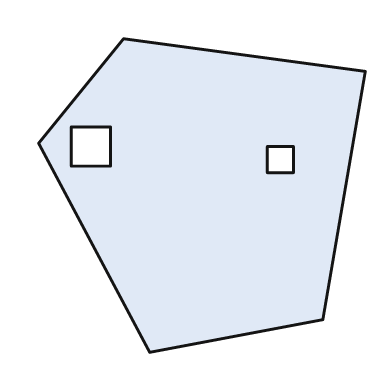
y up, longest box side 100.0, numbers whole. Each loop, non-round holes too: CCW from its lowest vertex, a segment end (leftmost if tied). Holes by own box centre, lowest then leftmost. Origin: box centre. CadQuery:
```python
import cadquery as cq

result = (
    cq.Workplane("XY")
    .moveTo(-16.0, -48.0)
    .lineTo(37.0, -38.0)
    .lineTo(50.0, 38.0)
    .lineTo(-24.0, 48.0)
    .lineTo(-50.0, 16.0)
    .close()
    .moveTo(20.0, 7.0)
    .lineTo(28.0, 7.0)
    .lineTo(28.0, 15.0)
    .lineTo(20.0, 15.0)
    .close()
    .moveTo(-40.0, 9.0)
    .lineTo(-28.0, 9.0)
    .lineTo(-28.0, 21.0)
    .lineTo(-40.0, 21.0)
    .close()
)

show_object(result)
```